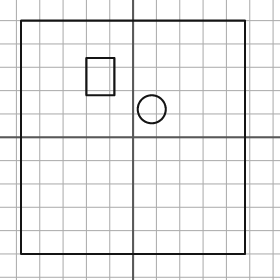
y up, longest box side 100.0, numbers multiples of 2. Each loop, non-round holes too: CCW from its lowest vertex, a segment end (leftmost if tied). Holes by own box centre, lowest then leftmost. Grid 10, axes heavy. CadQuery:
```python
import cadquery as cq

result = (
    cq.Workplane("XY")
    .moveTo(-48.0, -50.0)
    .lineTo(48.0, -50.0)
    .lineTo(48.0, 50.0)
    .lineTo(-48.0, 50.0)
    .close()
    .moveTo(8.0, 12.0)
    .circle(6.0)
    .moveTo(-20.0, 18.0)
    .lineTo(-8.0, 18.0)
    .lineTo(-8.0, 34.0)
    .lineTo(-20.0, 34.0)
    .close()
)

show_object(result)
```